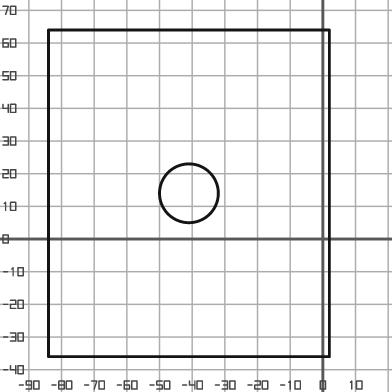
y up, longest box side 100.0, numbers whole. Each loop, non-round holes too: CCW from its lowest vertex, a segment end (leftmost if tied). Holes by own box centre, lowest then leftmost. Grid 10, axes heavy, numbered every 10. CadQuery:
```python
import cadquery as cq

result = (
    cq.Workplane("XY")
    .moveTo(-84.0, -36.0)
    .lineTo(2.0, -36.0)
    .lineTo(2.0, 64.0)
    .lineTo(-84.0, 64.0)
    .close()
    .moveTo(-41.0, 14.0)
    .circle(9.0)
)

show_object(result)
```